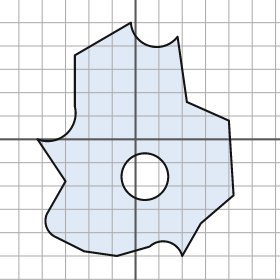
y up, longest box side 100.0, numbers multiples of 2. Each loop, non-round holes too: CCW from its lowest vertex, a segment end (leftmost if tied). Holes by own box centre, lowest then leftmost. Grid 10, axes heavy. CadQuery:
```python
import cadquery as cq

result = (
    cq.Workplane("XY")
    .moveTo(-8.0, -50.0)
    .lineTo(6.0, -46.0)
    .threePointArc((14.0, -44.0), (20.0, -50.0))
    .lineTo(28.0, -36.0)
    .lineTo(42.0, -24.0)
    .lineTo(40.0, 8.0)
    .lineTo(22.0, 16.0)
    .lineTo(18.0, 44.0)
    .threePointArc((6.0, 40.0), (-2.0, 50.0))
    .lineTo(-26.0, 36.0)
    .lineTo(-26.0, 14.0)
    .threePointArc((-30.0, 2.0), (-42.0, 0.0))
    .lineTo(-30.0, -18.0)
    .lineTo(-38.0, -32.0)
    .threePointArc((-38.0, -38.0), (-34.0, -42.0))
    .lineTo(-22.0, -48.0)
    .close()
    .moveTo(4.0, -16.0)
    .circle(10.0)
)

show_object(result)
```